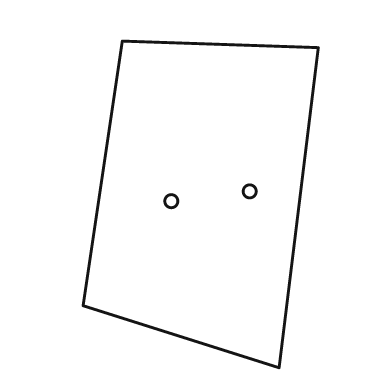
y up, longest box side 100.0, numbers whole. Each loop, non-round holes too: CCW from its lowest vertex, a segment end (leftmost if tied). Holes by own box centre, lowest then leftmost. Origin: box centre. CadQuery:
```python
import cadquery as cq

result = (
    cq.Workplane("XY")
    .moveTo(24.0, -50.0)
    .lineTo(36.0, 48.0)
    .lineTo(-24.0, 50.0)
    .lineTo(-36.0, -31.0)
    .close()
    .moveTo(-9.0, 1.0)
    .circle(2.0)
    .moveTo(15.0, 4.0)
    .circle(2.0)
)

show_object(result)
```